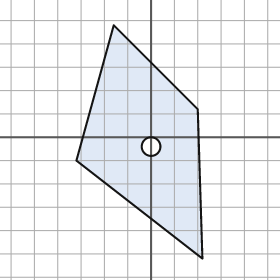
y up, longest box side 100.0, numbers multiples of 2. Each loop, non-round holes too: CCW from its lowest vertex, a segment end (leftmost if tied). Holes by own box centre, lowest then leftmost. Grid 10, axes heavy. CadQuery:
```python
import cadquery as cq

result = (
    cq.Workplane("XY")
    .moveTo(22.0, -52.0)
    .lineTo(20.0, 12.0)
    .lineTo(-16.0, 48.0)
    .lineTo(-32.0, -10.0)
    .close()
    .moveTo(0.0, -4.0)
    .circle(4.0)
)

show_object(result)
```